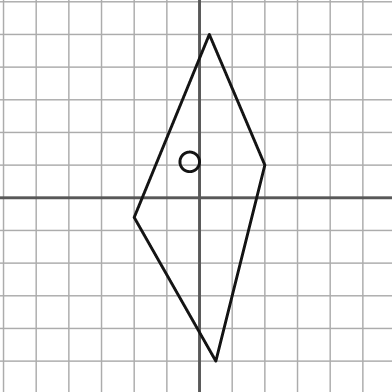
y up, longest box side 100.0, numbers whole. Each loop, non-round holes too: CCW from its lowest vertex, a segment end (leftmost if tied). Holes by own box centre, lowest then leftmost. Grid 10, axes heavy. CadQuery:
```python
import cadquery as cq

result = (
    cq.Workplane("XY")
    .moveTo(5.0, -50.0)
    .lineTo(20.0, 10.0)
    .lineTo(3.0, 50.0)
    .lineTo(-20.0, -6.0)
    .close()
    .moveTo(-3.0, 11.0)
    .circle(3.0)
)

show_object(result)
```